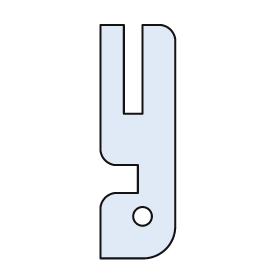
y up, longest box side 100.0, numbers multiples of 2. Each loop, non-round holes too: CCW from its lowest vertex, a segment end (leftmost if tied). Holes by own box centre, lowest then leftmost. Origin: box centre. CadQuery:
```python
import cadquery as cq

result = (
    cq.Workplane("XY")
    .moveTo(-16.0, -50.0)
    .lineTo(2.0, -50.0)
    .threePointArc((12.0, -46.0), (16.0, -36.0))
    .lineTo(16.0, 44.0)
    .threePointArc((14.0, 48.0), (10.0, 50.0))
    .lineTo(2.0, 50.0)
    .lineTo(2.0, 12.0)
    .lineTo(-6.0, 12.0)
    .lineTo(-6.0, 50.0)
    .lineTo(-16.0, 50.0)
    .lineTo(-16.0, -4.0)
    .threePointArc((-14.0, -8.0), (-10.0, -10.0))
    .lineTo(0.0, -10.0)
    .lineTo(0.0, -22.0)
    .lineTo(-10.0, -22.0)
    .threePointArc((-14.0, -24.0), (-16.0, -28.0))
    .close()
    .moveTo(2.0, -32.0)
    .circle(4.0)
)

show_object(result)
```